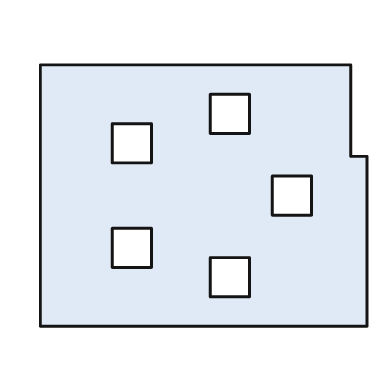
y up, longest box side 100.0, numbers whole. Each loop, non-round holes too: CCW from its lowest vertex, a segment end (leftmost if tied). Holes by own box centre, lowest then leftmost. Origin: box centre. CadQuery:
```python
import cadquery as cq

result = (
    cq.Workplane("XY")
    .moveTo(-50.0, -40.0)
    .lineTo(50.0, -40.0)
    .lineTo(50.0, 12.0)
    .lineTo(45.0, 12.0)
    .lineTo(45.0, 40.0)
    .lineTo(-50.0, 40.0)
    .close()
    .moveTo(2.0, -31.0)
    .lineTo(14.0, -31.0)
    .lineTo(14.0, -19.0)
    .lineTo(2.0, -19.0)
    .close()
    .moveTo(-28.0, -22.0)
    .lineTo(-16.0, -22.0)
    .lineTo(-16.0, -10.0)
    .lineTo(-28.0, -10.0)
    .close()
    .moveTo(21.0, -6.0)
    .lineTo(33.0, -6.0)
    .lineTo(33.0, 6.0)
    .lineTo(21.0, 6.0)
    .close()
    .moveTo(-28.0, 10.0)
    .lineTo(-16.0, 10.0)
    .lineTo(-16.0, 22.0)
    .lineTo(-28.0, 22.0)
    .close()
    .moveTo(2.0, 19.0)
    .lineTo(14.0, 19.0)
    .lineTo(14.0, 31.0)
    .lineTo(2.0, 31.0)
    .close()
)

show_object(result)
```